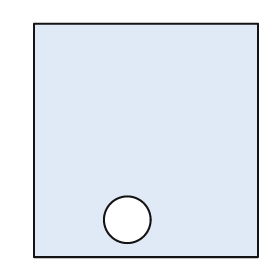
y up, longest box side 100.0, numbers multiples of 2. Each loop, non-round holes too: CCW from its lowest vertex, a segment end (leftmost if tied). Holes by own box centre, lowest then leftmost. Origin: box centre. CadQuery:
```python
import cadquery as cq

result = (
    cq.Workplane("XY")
    .moveTo(-48.0, -50.0)
    .lineTo(48.0, -50.0)
    .lineTo(48.0, 50.0)
    .lineTo(-48.0, 50.0)
    .close()
    .moveTo(-8.0, -34.0)
    .circle(10.0)
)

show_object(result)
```